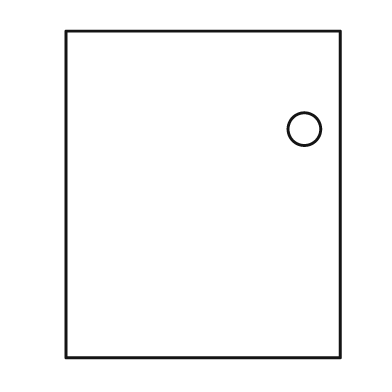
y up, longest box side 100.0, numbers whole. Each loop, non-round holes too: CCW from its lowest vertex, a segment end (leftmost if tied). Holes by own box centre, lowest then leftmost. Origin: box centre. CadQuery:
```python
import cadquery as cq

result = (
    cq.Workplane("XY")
    .moveTo(-42.0, -50.0)
    .lineTo(42.0, -50.0)
    .lineTo(42.0, 50.0)
    .lineTo(-42.0, 50.0)
    .close()
    .moveTo(31.0, 20.0)
    .circle(5.0)
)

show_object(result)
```